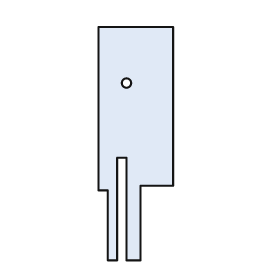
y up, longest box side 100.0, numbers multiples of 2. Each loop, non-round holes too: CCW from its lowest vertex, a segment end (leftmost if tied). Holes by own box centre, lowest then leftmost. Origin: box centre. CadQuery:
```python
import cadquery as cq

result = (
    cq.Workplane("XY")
    .moveTo(-12.0, -50.0)
    .lineTo(-8.0, -50.0)
    .lineTo(-8.0, -6.0)
    .lineTo(-4.0, -6.0)
    .lineTo(-4.0, -50.0)
    .lineTo(2.0, -50.0)
    .lineTo(2.0, -18.0)
    .lineTo(16.0, -18.0)
    .lineTo(16.0, 50.0)
    .lineTo(-16.0, 50.0)
    .lineTo(-16.0, -20.0)
    .lineTo(-12.0, -20.0)
    .close()
    .moveTo(-4.0, 26.0)
    .circle(2.0)
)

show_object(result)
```